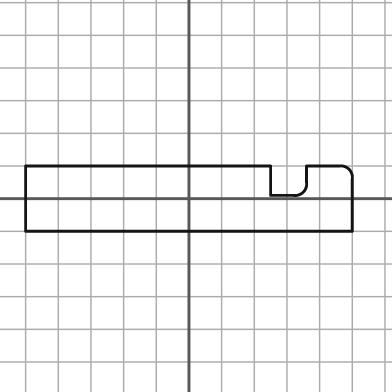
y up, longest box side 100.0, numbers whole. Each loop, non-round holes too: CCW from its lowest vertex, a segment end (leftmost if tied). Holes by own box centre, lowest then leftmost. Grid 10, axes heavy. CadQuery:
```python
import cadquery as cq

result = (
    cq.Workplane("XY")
    .moveTo(-50.0, -10.0)
    .lineTo(50.0, -10.0)
    .lineTo(50.0, 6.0)
    .threePointArc((49.0, 9.0), (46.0, 10.0))
    .lineTo(36.0, 10.0)
    .lineTo(36.0, 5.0)
    .threePointArc((35.0, 2.0), (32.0, 1.0))
    .lineTo(25.0, 1.0)
    .lineTo(25.0, 10.0)
    .lineTo(-50.0, 10.0)
    .close()
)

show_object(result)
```